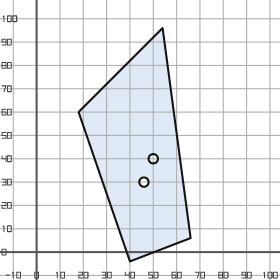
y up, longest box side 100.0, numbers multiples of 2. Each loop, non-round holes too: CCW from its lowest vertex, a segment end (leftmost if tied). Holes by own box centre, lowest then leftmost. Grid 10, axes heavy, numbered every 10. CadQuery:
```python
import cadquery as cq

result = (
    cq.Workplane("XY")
    .moveTo(40.0, -4.0)
    .lineTo(66.0, 6.0)
    .lineTo(54.0, 96.0)
    .lineTo(18.0, 60.0)
    .close()
    .moveTo(46.0, 30.0)
    .circle(2.0)
    .moveTo(50.0, 40.0)
    .circle(2.0)
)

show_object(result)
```